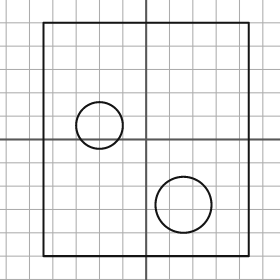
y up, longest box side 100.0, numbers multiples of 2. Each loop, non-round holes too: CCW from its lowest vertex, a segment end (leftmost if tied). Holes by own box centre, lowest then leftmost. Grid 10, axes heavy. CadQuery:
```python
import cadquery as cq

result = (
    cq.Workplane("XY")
    .moveTo(-44.0, -50.0)
    .lineTo(44.0, -50.0)
    .lineTo(44.0, 50.0)
    .lineTo(-44.0, 50.0)
    .close()
    .moveTo(16.0, -28.0)
    .circle(12.0)
    .moveTo(-20.0, 6.0)
    .circle(10.0)
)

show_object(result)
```